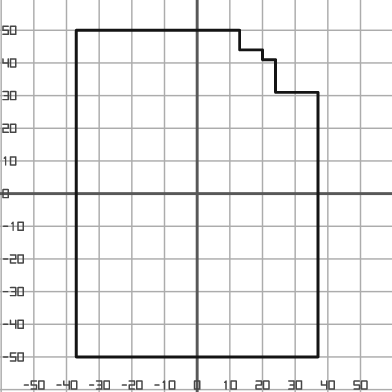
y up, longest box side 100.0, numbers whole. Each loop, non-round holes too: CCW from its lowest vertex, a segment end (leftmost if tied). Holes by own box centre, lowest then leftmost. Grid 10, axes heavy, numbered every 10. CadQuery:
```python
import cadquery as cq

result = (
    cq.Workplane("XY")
    .moveTo(-37.0, -50.0)
    .lineTo(37.0, -50.0)
    .lineTo(37.0, 31.0)
    .lineTo(24.0, 31.0)
    .lineTo(24.0, 41.0)
    .lineTo(20.0, 41.0)
    .lineTo(20.0, 44.0)
    .lineTo(13.0, 44.0)
    .lineTo(13.0, 50.0)
    .lineTo(-37.0, 50.0)
    .close()
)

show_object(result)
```